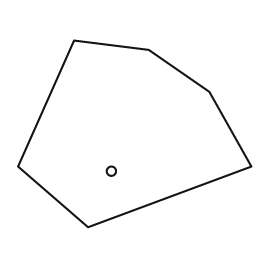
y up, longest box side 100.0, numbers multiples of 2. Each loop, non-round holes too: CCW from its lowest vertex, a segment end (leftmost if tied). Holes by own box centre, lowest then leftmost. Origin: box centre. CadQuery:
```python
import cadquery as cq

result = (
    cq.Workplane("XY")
    .moveTo(-20.0, -40.0)
    .lineTo(50.0, -14.0)
    .lineTo(32.0, 18.0)
    .lineTo(6.0, 36.0)
    .lineTo(-26.0, 40.0)
    .lineTo(-50.0, -14.0)
    .close()
    .moveTo(-10.0, -16.0)
    .circle(2.0)
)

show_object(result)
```